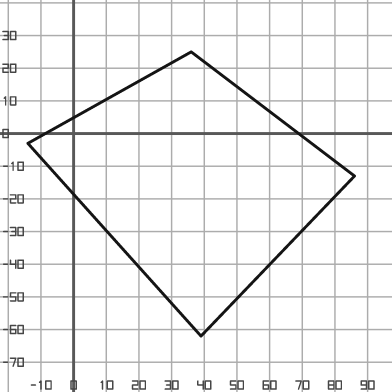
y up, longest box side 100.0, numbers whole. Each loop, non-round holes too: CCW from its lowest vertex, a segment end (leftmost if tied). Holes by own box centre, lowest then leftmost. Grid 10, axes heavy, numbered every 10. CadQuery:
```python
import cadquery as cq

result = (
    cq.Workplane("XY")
    .moveTo(39.0, -62.0)
    .lineTo(86.0, -13.0)
    .lineTo(36.0, 25.0)
    .lineTo(-14.0, -3.0)
    .close()
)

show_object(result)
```